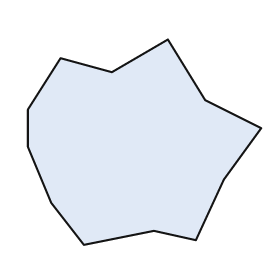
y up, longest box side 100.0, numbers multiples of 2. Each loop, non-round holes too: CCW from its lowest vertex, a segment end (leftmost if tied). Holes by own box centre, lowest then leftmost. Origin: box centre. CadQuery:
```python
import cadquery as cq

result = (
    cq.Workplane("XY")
    .moveTo(-26.0, -44.0)
    .lineTo(4.0, -38.0)
    .lineTo(22.0, -42.0)
    .lineTo(34.0, -16.0)
    .lineTo(50.0, 6.0)
    .lineTo(26.0, 18.0)
    .lineTo(10.0, 44.0)
    .lineTo(-14.0, 30.0)
    .lineTo(-36.0, 36.0)
    .lineTo(-50.0, 14.0)
    .lineTo(-50.0, -2.0)
    .lineTo(-40.0, -26.0)
    .close()
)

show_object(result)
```